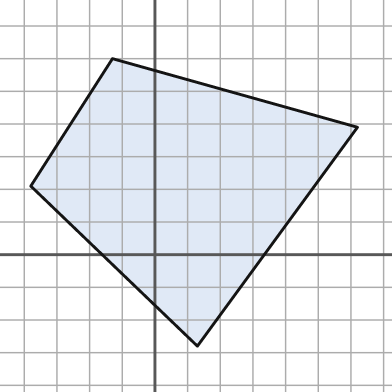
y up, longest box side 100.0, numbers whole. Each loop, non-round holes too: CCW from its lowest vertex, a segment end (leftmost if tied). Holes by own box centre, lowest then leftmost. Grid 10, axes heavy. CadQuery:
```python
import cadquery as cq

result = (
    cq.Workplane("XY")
    .moveTo(13.0, -28.0)
    .lineTo(62.0, 39.0)
    .lineTo(-13.0, 60.0)
    .lineTo(-38.0, 21.0)
    .close()
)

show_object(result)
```